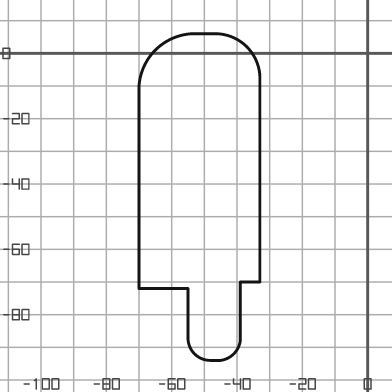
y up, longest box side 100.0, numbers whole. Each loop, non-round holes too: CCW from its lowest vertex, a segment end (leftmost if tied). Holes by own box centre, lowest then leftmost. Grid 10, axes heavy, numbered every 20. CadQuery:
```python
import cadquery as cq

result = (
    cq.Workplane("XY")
    .moveTo(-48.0, -94.0)
    .lineTo(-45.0, -94.0)
    .threePointArc((-41.0, -92.0), (-39.0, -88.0))
    .lineTo(-39.0, -70.0)
    .lineTo(-33.0, -70.0)
    .lineTo(-33.0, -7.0)
    .threePointArc((-37.0, 2.0), (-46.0, 6.0))
    .lineTo(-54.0, 6.0)
    .threePointArc((-65.0, 1.0), (-70.0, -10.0))
    .lineTo(-70.0, -72.0)
    .lineTo(-55.0, -72.0)
    .lineTo(-55.0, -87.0)
    .threePointArc((-53.0, -92.0), (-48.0, -94.0))
    .close()
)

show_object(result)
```